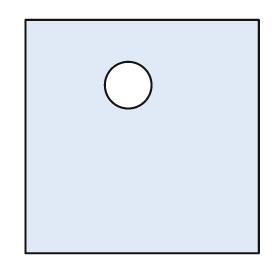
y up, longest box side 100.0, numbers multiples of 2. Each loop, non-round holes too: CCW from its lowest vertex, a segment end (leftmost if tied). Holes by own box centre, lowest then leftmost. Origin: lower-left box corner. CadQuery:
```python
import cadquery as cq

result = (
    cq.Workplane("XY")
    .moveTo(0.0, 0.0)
    .lineTo(100.0, 0.0)
    .lineTo(100.0, 100.0)
    .lineTo(0.0, 100.0)
    .close()
    .moveTo(44.0, 72.0)
    .circle(10.0)
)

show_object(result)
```